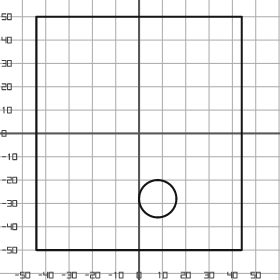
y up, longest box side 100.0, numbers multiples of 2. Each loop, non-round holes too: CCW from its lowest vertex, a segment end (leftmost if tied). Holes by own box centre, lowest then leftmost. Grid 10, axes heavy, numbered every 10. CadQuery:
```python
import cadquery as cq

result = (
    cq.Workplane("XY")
    .moveTo(-44.0, -50.0)
    .lineTo(44.0, -50.0)
    .lineTo(44.0, 50.0)
    .lineTo(-44.0, 50.0)
    .close()
    .moveTo(8.0, -28.0)
    .circle(8.0)
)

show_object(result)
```